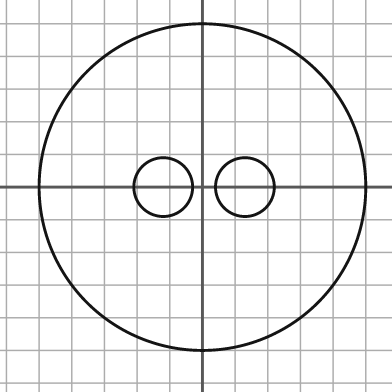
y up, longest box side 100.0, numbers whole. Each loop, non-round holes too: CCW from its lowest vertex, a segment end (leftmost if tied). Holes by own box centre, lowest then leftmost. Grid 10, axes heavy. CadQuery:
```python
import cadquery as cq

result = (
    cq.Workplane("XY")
    .moveTo(0.0, 0.0)
    .circle(50.0)
    .moveTo(-12.0, 0.0)
    .circle(9.0)
    .moveTo(13.0, 0.0)
    .circle(9.0)
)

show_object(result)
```